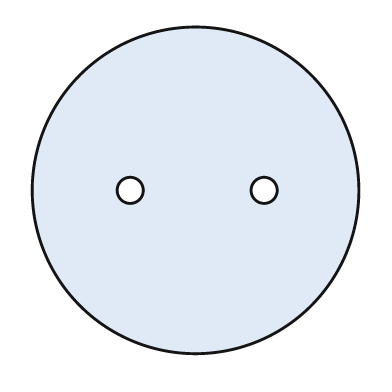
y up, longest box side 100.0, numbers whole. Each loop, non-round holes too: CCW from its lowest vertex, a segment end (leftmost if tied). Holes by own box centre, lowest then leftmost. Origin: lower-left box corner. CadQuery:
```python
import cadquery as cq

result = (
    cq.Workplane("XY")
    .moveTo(50.0, 50.0)
    .circle(50.0)
    .moveTo(30.0, 50.0)
    .circle(4.0)
    .moveTo(71.0, 50.0)
    .circle(4.0)
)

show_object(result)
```